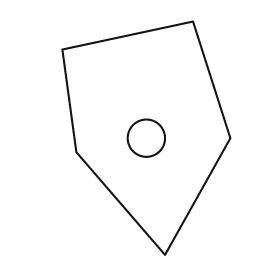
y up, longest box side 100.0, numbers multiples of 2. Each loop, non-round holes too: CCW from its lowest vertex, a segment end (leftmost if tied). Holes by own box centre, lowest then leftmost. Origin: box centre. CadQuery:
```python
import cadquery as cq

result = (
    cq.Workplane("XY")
    .moveTo(8.0, -50.0)
    .lineTo(36.0, 0.0)
    .lineTo(20.0, 50.0)
    .lineTo(-36.0, 38.0)
    .lineTo(-30.0, -6.0)
    .close()
    .moveTo(0.0, 0.0)
    .circle(8.0)
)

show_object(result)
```